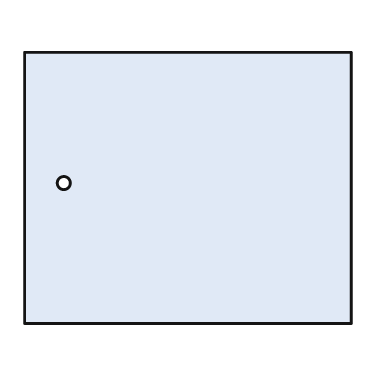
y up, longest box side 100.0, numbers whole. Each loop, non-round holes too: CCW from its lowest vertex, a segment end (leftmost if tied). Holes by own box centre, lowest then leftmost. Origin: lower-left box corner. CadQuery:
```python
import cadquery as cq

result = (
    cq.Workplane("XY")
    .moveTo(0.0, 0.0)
    .lineTo(100.0, 0.0)
    .lineTo(100.0, 83.0)
    .lineTo(0.0, 83.0)
    .close()
    .moveTo(12.0, 43.0)
    .circle(2.0)
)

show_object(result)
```